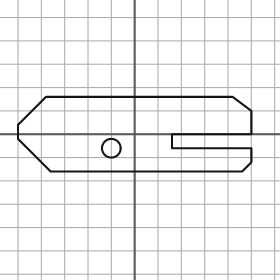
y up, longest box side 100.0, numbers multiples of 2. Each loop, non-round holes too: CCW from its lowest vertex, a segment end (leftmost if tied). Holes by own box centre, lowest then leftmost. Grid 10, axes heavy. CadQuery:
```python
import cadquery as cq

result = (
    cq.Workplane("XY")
    .moveTo(-36.0, -16.0)
    .lineTo(46.0, -16.0)
    .lineTo(50.0, -12.0)
    .lineTo(50.0, -6.0)
    .lineTo(16.0, -6.0)
    .lineTo(16.0, 0.0)
    .lineTo(50.0, 0.0)
    .lineTo(50.0, 10.0)
    .lineTo(42.0, 16.0)
    .lineTo(-38.0, 16.0)
    .lineTo(-50.0, 4.0)
    .lineTo(-50.0, -2.0)
    .close()
    .moveTo(-10.0, -6.0)
    .circle(4.0)
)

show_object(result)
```